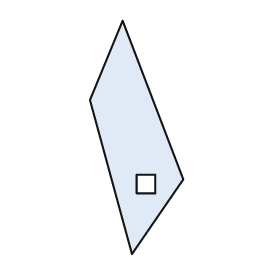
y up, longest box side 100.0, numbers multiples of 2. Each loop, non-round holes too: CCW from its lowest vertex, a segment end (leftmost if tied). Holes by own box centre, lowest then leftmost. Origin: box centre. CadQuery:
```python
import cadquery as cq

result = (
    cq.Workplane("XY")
    .moveTo(-2.0, -50.0)
    .lineTo(20.0, -18.0)
    .lineTo(-6.0, 50.0)
    .lineTo(-20.0, 16.0)
    .close()
    .moveTo(0.0, -24.0)
    .lineTo(8.0, -24.0)
    .lineTo(8.0, -16.0)
    .lineTo(0.0, -16.0)
    .close()
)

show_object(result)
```